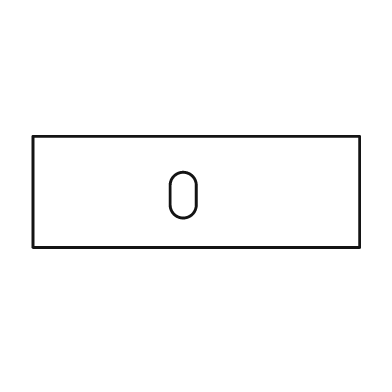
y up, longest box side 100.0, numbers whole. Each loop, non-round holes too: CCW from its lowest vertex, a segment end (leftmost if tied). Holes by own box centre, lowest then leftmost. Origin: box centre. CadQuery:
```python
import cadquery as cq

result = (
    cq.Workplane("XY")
    .moveTo(-50.0, -17.0)
    .lineTo(50.0, -17.0)
    .lineTo(50.0, 17.0)
    .lineTo(-50.0, 17.0)
    .close()
    .moveTo(-8.0, -4.0)
    .threePointArc((-4.0, -8.0), (0.0, -4.0))
    .lineTo(0.0, 2.0)
    .threePointArc((-4.0, 6.0), (-8.0, 2.0))
    .close()
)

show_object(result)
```